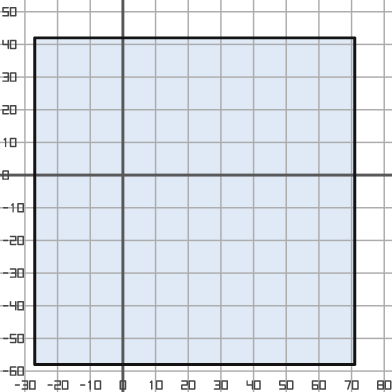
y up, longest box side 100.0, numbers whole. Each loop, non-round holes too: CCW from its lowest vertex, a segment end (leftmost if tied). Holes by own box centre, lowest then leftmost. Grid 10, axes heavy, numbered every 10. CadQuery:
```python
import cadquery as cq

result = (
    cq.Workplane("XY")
    .moveTo(-27.0, -58.0)
    .lineTo(71.0, -58.0)
    .lineTo(71.0, 42.0)
    .lineTo(-27.0, 42.0)
    .close()
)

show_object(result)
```